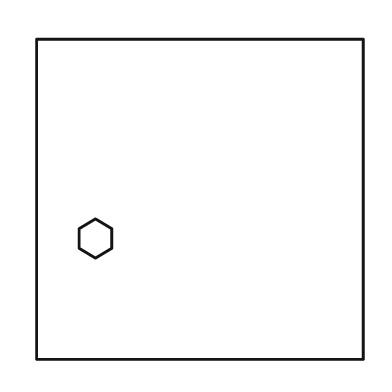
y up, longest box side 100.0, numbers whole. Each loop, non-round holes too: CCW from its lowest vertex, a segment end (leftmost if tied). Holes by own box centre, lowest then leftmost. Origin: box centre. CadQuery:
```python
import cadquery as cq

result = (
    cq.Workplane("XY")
    .moveTo(-50.0, -49.0)
    .lineTo(50.0, -49.0)
    .lineTo(50.0, 49.0)
    .lineTo(-50.0, 49.0)
    .close()
    .moveTo(-32.0, -18.0)
    .lineTo(-27.0, -15.0)
    .lineTo(-27.0, -9.0)
    .lineTo(-32.0, -6.0)
    .lineTo(-37.0, -9.0)
    .lineTo(-37.0, -15.0)
    .close()
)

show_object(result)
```